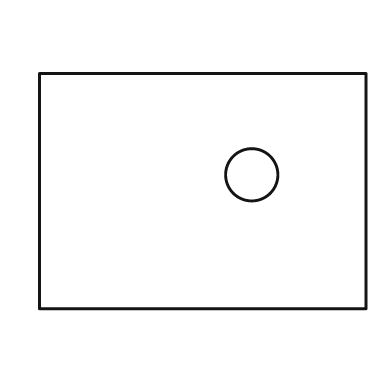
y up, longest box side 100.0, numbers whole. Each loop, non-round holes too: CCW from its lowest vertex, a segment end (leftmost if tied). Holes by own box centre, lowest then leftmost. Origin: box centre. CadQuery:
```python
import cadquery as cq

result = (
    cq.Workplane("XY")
    .moveTo(-50.0, -36.0)
    .lineTo(50.0, -36.0)
    .lineTo(50.0, 36.0)
    .lineTo(-50.0, 36.0)
    .close()
    .moveTo(15.0, 5.0)
    .circle(8.0)
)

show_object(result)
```